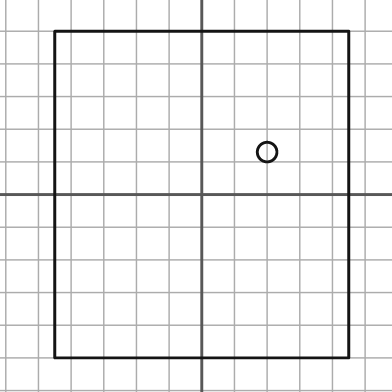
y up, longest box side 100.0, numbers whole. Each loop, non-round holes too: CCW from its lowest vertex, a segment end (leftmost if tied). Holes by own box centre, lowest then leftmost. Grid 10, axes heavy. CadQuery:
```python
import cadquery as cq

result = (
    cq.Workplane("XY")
    .moveTo(-45.0, -50.0)
    .lineTo(45.0, -50.0)
    .lineTo(45.0, 50.0)
    .lineTo(-45.0, 50.0)
    .close()
    .moveTo(20.0, 13.0)
    .circle(3.0)
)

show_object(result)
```